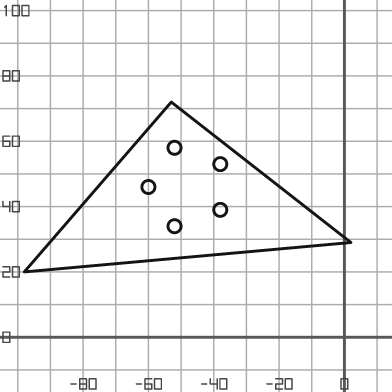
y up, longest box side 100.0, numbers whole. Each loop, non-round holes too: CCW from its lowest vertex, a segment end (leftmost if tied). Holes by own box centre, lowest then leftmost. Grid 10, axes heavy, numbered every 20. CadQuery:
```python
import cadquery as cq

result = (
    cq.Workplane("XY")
    .moveTo(-98.0, 20.0)
    .lineTo(2.0, 29.0)
    .lineTo(-53.0, 72.0)
    .close()
    .moveTo(-52.0, 34.0)
    .circle(2.0)
    .moveTo(-38.0, 39.0)
    .circle(2.0)
    .moveTo(-60.0, 46.0)
    .circle(2.0)
    .moveTo(-38.0, 53.0)
    .circle(2.0)
    .moveTo(-52.0, 58.0)
    .circle(2.0)
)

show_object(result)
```